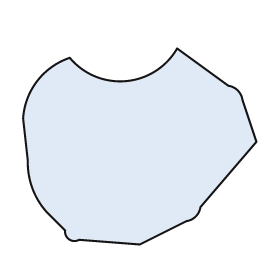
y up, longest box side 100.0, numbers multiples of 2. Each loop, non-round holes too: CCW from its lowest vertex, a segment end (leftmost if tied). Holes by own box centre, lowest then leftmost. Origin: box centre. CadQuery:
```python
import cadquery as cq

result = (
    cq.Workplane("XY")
    .moveTo(0.0, -42.0)
    .lineTo(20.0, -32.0)
    .threePointArc((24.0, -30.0), (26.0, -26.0))
    .lineTo(50.0, 2.0)
    .lineTo(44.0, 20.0)
    .threePointArc((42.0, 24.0), (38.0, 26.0))
    .lineTo(16.0, 42.0)
    .threePointArc((-6.0, 28.0), (-30.0, 38.0))
    .threePointArc((-44.0, 28.0), (-50.0, 12.0))
    .lineTo(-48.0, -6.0)
    .threePointArc((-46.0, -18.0), (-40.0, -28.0))
    .lineTo(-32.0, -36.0)
    .threePointArc((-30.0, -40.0), (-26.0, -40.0))
    .close()
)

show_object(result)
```